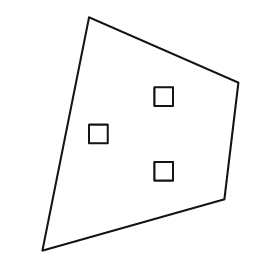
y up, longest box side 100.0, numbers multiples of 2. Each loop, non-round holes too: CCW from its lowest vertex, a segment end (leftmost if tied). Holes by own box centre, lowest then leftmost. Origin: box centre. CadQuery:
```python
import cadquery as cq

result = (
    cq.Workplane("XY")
    .moveTo(-42.0, -50.0)
    .lineTo(36.0, -28.0)
    .lineTo(42.0, 22.0)
    .lineTo(-22.0, 50.0)
    .close()
    .moveTo(6.0, -20.0)
    .lineTo(14.0, -20.0)
    .lineTo(14.0, -12.0)
    .lineTo(6.0, -12.0)
    .close()
    .moveTo(-22.0, -4.0)
    .lineTo(-14.0, -4.0)
    .lineTo(-14.0, 4.0)
    .lineTo(-22.0, 4.0)
    .close()
    .moveTo(6.0, 12.0)
    .lineTo(14.0, 12.0)
    .lineTo(14.0, 20.0)
    .lineTo(6.0, 20.0)
    .close()
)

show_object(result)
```